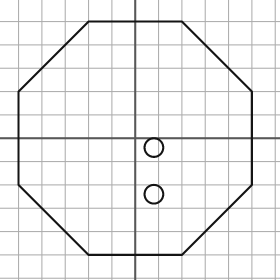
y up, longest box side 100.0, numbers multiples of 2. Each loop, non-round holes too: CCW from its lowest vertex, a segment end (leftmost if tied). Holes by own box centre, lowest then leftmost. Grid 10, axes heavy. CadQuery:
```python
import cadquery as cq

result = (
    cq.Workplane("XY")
    .moveTo(-20.0, -50.0)
    .lineTo(20.0, -50.0)
    .lineTo(50.0, -20.0)
    .lineTo(50.0, 20.0)
    .lineTo(20.0, 50.0)
    .lineTo(-20.0, 50.0)
    .lineTo(-50.0, 20.0)
    .lineTo(-50.0, -20.0)
    .close()
    .moveTo(8.0, -24.0)
    .circle(4.0)
    .moveTo(8.0, -4.0)
    .circle(4.0)
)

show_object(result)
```